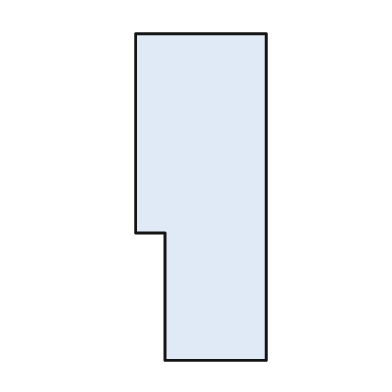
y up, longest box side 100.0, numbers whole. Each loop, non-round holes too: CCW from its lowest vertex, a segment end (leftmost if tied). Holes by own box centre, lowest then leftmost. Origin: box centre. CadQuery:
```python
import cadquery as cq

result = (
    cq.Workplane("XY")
    .moveTo(-11.0, -50.0)
    .lineTo(20.0, -50.0)
    .lineTo(20.0, 50.0)
    .lineTo(-20.0, 50.0)
    .lineTo(-20.0, -11.0)
    .lineTo(-11.0, -11.0)
    .close()
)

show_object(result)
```